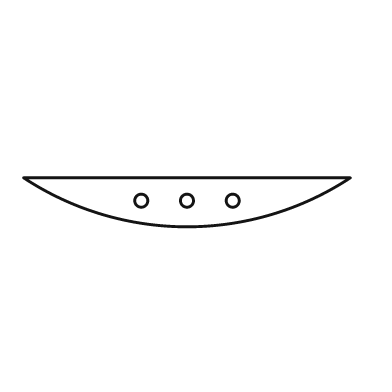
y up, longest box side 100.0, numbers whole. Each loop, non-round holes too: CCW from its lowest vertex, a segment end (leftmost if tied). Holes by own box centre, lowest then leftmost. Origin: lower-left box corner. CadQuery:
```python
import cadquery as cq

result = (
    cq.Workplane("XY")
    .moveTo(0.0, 15.0)
    .threePointArc((50.0, 0.0), (100.0, 15.0))
    .close()
    .moveTo(36.0, 8.0)
    .circle(2.0)
    .moveTo(50.0, 8.0)
    .circle(2.0)
    .moveTo(64.0, 8.0)
    .circle(2.0)
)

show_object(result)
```